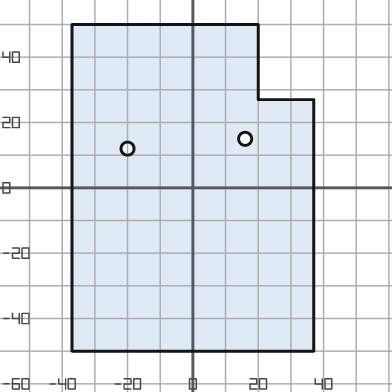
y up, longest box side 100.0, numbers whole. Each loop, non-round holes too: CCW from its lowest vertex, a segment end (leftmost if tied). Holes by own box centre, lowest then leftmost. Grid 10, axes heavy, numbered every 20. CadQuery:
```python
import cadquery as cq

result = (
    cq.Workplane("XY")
    .moveTo(-37.0, -50.0)
    .lineTo(37.0, -50.0)
    .lineTo(37.0, 27.0)
    .lineTo(20.0, 27.0)
    .lineTo(20.0, 50.0)
    .lineTo(-37.0, 50.0)
    .close()
    .moveTo(-20.0, 12.0)
    .circle(2.0)
    .moveTo(16.0, 15.0)
    .circle(2.0)
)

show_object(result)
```